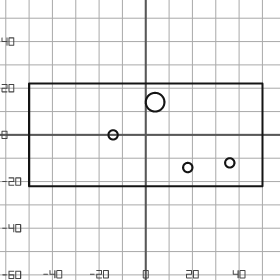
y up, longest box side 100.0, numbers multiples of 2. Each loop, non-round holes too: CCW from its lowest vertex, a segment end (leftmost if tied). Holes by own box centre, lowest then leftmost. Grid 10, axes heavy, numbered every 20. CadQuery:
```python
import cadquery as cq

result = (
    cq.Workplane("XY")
    .moveTo(-50.0, -22.0)
    .lineTo(50.0, -22.0)
    .lineTo(50.0, 22.0)
    .lineTo(-50.0, 22.0)
    .close()
    .moveTo(18.0, -14.0)
    .circle(2.0)
    .moveTo(36.0, -12.0)
    .circle(2.0)
    .moveTo(-14.0, 0.0)
    .circle(2.0)
    .moveTo(4.0, 14.0)
    .circle(4.0)
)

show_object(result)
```